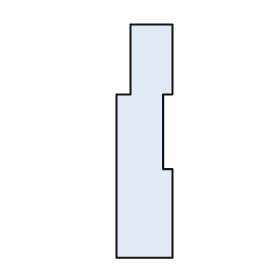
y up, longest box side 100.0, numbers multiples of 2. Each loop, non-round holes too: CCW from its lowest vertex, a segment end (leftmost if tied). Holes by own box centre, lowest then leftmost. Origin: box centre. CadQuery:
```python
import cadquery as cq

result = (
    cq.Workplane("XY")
    .moveTo(-12.0, -50.0)
    .lineTo(12.0, -50.0)
    .lineTo(12.0, -12.0)
    .lineTo(8.0, -12.0)
    .lineTo(8.0, 20.0)
    .lineTo(12.0, 20.0)
    .lineTo(12.0, 50.0)
    .lineTo(-6.0, 50.0)
    .lineTo(-6.0, 20.0)
    .lineTo(-12.0, 20.0)
    .close()
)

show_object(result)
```